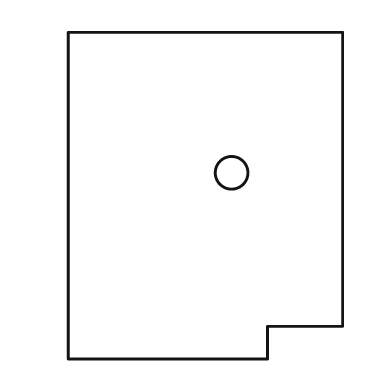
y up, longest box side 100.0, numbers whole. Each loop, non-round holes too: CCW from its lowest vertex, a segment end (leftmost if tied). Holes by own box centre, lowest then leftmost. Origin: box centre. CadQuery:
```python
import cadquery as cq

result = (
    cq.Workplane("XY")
    .moveTo(-42.0, -50.0)
    .lineTo(19.0, -50.0)
    .lineTo(19.0, -40.0)
    .lineTo(42.0, -40.0)
    .lineTo(42.0, 50.0)
    .lineTo(-42.0, 50.0)
    .close()
    .moveTo(8.0, 7.0)
    .circle(5.0)
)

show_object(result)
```